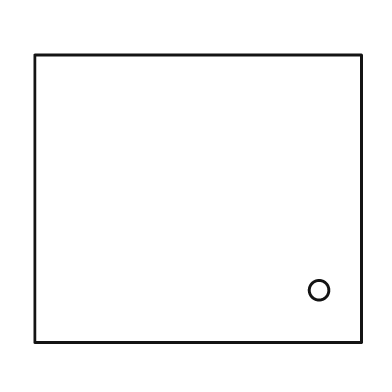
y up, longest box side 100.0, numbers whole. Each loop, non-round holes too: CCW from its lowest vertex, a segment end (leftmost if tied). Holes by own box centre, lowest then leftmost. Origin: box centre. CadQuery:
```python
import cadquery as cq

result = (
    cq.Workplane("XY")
    .moveTo(-50.0, -44.0)
    .lineTo(50.0, -44.0)
    .lineTo(50.0, 44.0)
    .lineTo(-50.0, 44.0)
    .close()
    .moveTo(37.0, -28.0)
    .circle(3.0)
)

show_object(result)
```